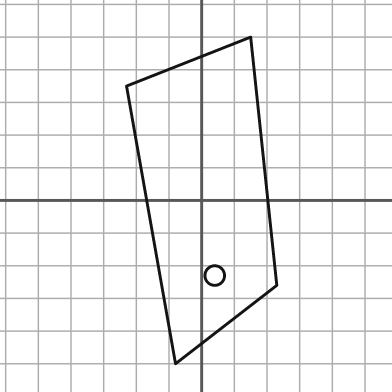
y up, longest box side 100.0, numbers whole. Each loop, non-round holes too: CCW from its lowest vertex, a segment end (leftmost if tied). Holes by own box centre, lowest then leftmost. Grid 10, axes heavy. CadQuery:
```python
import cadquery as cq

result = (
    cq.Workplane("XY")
    .moveTo(-8.0, -50.0)
    .lineTo(23.0, -26.0)
    .lineTo(15.0, 50.0)
    .lineTo(-23.0, 35.0)
    .close()
    .moveTo(4.0, -23.0)
    .circle(3.0)
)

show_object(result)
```